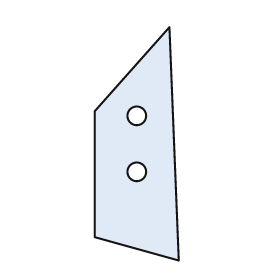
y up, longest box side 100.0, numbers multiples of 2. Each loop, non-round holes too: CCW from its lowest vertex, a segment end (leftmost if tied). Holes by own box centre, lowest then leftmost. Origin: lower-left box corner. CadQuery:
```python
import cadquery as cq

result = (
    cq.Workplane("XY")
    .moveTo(36.0, 0.0)
    .lineTo(32.0, 100.0)
    .lineTo(0.0, 64.0)
    .lineTo(0.0, 10.0)
    .close()
    .moveTo(18.0, 38.0)
    .circle(4.0)
    .moveTo(18.0, 62.0)
    .circle(4.0)
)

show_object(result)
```